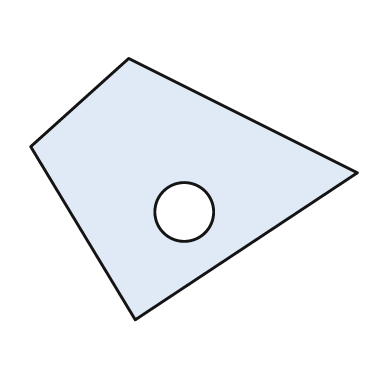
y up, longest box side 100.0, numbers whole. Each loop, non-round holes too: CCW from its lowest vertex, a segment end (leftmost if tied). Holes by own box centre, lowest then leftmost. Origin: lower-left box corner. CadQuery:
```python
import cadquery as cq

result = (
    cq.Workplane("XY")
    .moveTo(32.0, 0.0)
    .lineTo(100.0, 45.0)
    .lineTo(30.0, 80.0)
    .lineTo(0.0, 53.0)
    .close()
    .moveTo(47.0, 33.0)
    .circle(9.0)
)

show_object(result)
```